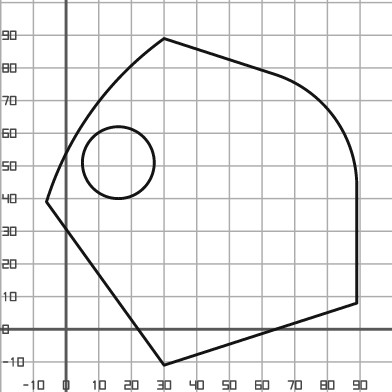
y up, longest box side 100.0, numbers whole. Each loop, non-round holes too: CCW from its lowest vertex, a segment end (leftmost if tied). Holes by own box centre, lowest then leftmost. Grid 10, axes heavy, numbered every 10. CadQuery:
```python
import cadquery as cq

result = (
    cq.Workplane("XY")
    .moveTo(30.0, -11.0)
    .lineTo(89.0, 8.0)
    .lineTo(89.0, 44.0)
    .threePointArc((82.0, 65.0), (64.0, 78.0))
    .lineTo(30.0, 89.0)
    .threePointArc((8.0, 67.0), (-6.0, 39.0))
    .close()
    .moveTo(16.0, 51.0)
    .circle(11.0)
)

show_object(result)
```